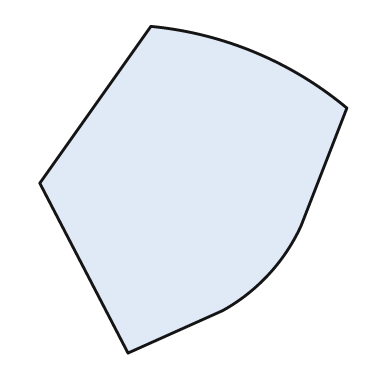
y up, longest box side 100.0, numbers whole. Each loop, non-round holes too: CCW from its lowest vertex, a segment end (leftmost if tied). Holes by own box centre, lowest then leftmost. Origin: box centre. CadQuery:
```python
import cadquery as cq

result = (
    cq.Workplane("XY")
    .moveTo(-20.0, -50.0)
    .lineTo(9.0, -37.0)
    .threePointArc((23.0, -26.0), (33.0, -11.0))
    .lineTo(47.0, 25.0)
    .threePointArc((19.0, 42.0), (-13.0, 50.0))
    .lineTo(-47.0, 2.0)
    .close()
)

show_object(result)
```